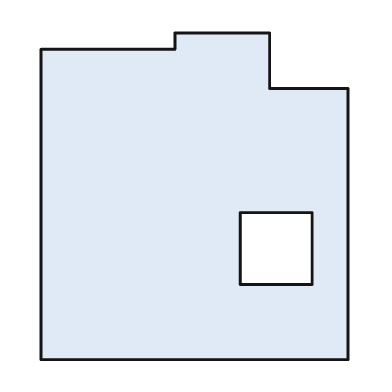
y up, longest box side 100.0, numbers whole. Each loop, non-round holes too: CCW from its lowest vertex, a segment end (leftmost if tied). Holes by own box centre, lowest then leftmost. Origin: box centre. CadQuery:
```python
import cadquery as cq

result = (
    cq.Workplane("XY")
    .moveTo(-47.0, -50.0)
    .lineTo(47.0, -50.0)
    .lineTo(47.0, 33.0)
    .lineTo(23.0, 33.0)
    .lineTo(23.0, 50.0)
    .lineTo(-6.0, 50.0)
    .lineTo(-6.0, 45.0)
    .lineTo(-47.0, 45.0)
    .close()
    .moveTo(14.0, -27.0)
    .lineTo(36.0, -27.0)
    .lineTo(36.0, -5.0)
    .lineTo(14.0, -5.0)
    .close()
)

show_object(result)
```